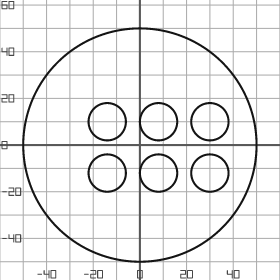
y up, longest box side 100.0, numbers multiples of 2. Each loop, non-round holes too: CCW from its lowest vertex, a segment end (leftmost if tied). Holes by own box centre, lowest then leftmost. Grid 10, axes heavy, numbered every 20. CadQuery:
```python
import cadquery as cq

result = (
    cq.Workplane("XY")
    .moveTo(0.0, 0.0)
    .circle(50.0)
    .moveTo(-14.0, -12.0)
    .circle(8.0)
    .moveTo(8.0, -12.0)
    .circle(8.0)
    .moveTo(30.0, -12.0)
    .circle(8.0)
    .moveTo(-14.0, 10.0)
    .circle(8.0)
    .moveTo(8.0, 10.0)
    .circle(8.0)
    .moveTo(30.0, 10.0)
    .circle(8.0)
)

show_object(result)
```